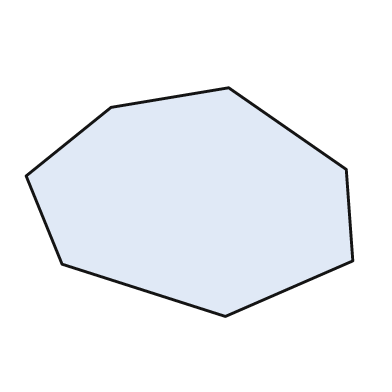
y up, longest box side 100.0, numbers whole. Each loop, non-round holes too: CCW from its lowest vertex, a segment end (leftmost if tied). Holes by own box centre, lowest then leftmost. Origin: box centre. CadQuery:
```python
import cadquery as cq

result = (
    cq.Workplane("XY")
    .moveTo(11.0, -35.0)
    .lineTo(50.0, -18.0)
    .lineTo(48.0, 10.0)
    .lineTo(12.0, 35.0)
    .lineTo(-24.0, 29.0)
    .lineTo(-50.0, 8.0)
    .lineTo(-39.0, -19.0)
    .close()
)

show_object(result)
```